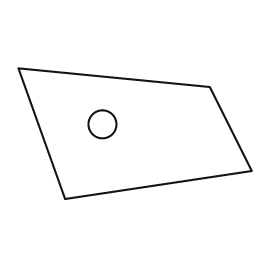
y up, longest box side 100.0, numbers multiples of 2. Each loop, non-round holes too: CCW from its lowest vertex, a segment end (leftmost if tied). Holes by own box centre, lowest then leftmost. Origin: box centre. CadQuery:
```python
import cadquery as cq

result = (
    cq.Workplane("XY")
    .moveTo(-30.0, -28.0)
    .lineTo(50.0, -16.0)
    .lineTo(32.0, 20.0)
    .lineTo(-50.0, 28.0)
    .close()
    .moveTo(-14.0, 4.0)
    .circle(6.0)
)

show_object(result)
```